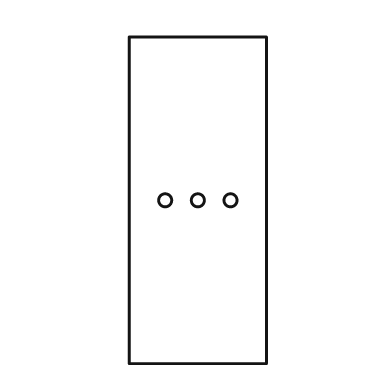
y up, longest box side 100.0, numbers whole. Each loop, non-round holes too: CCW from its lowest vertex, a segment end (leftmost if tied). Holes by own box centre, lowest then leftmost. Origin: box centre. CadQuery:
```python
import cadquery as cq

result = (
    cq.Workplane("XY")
    .moveTo(-21.0, -50.0)
    .lineTo(21.0, -50.0)
    .lineTo(21.0, 50.0)
    .lineTo(-21.0, 50.0)
    .close()
    .moveTo(-10.0, 0.0)
    .circle(2.0)
    .moveTo(0.0, 0.0)
    .circle(2.0)
    .moveTo(10.0, 0.0)
    .circle(2.0)
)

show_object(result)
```